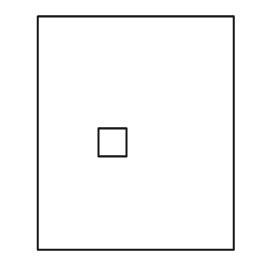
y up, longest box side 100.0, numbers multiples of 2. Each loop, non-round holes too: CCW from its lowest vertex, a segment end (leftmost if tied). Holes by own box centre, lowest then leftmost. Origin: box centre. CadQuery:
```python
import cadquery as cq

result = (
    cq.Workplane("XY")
    .moveTo(-42.0, -50.0)
    .lineTo(42.0, -50.0)
    .lineTo(42.0, 50.0)
    .lineTo(-42.0, 50.0)
    .close()
    .moveTo(-16.0, -10.0)
    .lineTo(-4.0, -10.0)
    .lineTo(-4.0, 2.0)
    .lineTo(-16.0, 2.0)
    .close()
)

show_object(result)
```